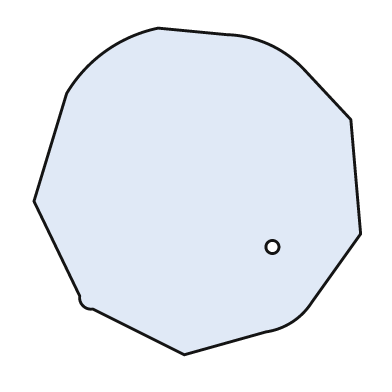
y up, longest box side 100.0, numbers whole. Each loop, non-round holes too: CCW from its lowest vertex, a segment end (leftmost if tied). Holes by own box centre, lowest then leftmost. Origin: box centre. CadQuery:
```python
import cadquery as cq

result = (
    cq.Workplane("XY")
    .moveTo(-4.0, -50.0)
    .lineTo(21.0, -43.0)
    .threePointArc((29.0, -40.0), (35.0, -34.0))
    .lineTo(50.0, -13.0)
    .lineTo(47.0, 22.0)
    .lineTo(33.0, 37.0)
    .threePointArc((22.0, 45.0), (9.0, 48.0))
    .lineTo(-12.0, 50.0)
    .threePointArc((-28.0, 43.0), (-40.0, 30.0))
    .lineTo(-50.0, -3.0)
    .lineTo(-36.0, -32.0)
    .threePointArc((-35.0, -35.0), (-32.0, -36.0))
    .close()
    .moveTo(23.0, -17.0)
    .circle(2.0)
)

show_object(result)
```